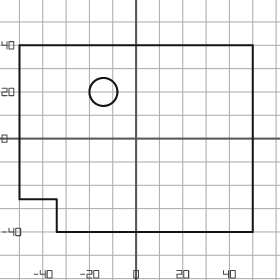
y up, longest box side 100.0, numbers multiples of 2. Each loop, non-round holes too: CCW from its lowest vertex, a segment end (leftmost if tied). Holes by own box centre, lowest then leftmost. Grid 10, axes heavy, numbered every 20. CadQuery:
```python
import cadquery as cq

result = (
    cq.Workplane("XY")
    .moveTo(-34.0, -40.0)
    .lineTo(50.0, -40.0)
    .lineTo(50.0, 40.0)
    .lineTo(-50.0, 40.0)
    .lineTo(-50.0, -26.0)
    .lineTo(-34.0, -26.0)
    .close()
    .moveTo(-14.0, 20.0)
    .circle(6.0)
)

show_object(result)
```